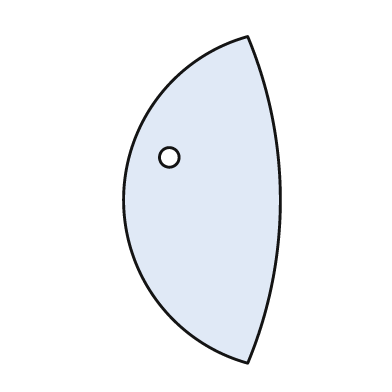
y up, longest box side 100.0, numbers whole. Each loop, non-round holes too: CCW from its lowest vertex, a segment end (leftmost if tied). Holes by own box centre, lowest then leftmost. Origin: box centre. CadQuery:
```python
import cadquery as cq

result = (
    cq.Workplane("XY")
    .moveTo(14.0, -50.0)
    .threePointArc((24.0, 0.0), (14.0, 50.0))
    .threePointArc((-24.0, 0.0), (14.0, -50.0))
    .close()
    .moveTo(-10.0, 13.0)
    .circle(3.0)
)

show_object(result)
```